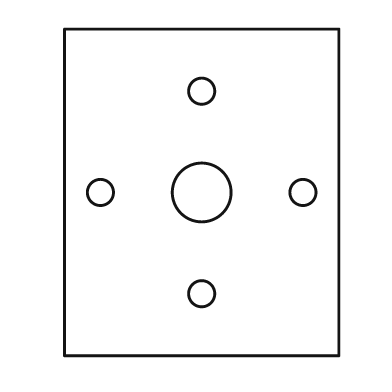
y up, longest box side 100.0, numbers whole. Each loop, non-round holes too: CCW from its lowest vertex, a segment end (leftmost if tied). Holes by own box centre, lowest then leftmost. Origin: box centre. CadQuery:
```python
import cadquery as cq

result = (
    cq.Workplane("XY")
    .moveTo(-42.0, -50.0)
    .lineTo(42.0, -50.0)
    .lineTo(42.0, 50.0)
    .lineTo(-42.0, 50.0)
    .close()
    .moveTo(0.0, -31.0)
    .circle(4.0)
    .moveTo(-31.0, 0.0)
    .circle(4.0)
    .moveTo(0.0, 0.0)
    .circle(9.0)
    .moveTo(31.0, 0.0)
    .circle(4.0)
    .moveTo(0.0, 31.0)
    .circle(4.0)
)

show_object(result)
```